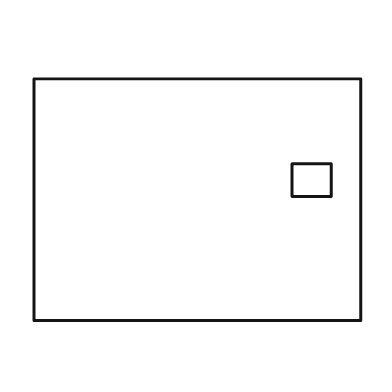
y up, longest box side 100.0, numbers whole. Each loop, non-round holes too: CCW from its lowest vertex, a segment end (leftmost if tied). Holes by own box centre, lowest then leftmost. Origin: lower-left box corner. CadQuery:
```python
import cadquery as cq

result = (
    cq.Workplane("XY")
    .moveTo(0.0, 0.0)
    .lineTo(100.0, 0.0)
    .lineTo(100.0, 74.0)
    .lineTo(0.0, 74.0)
    .close()
    .moveTo(79.0, 38.0)
    .lineTo(91.0, 38.0)
    .lineTo(91.0, 48.0)
    .lineTo(79.0, 48.0)
    .close()
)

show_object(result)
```